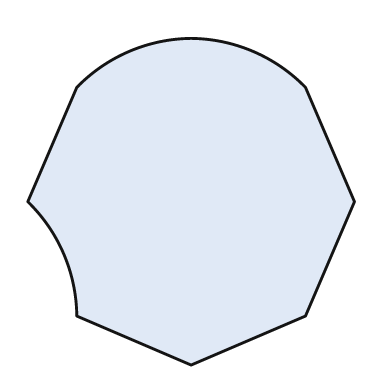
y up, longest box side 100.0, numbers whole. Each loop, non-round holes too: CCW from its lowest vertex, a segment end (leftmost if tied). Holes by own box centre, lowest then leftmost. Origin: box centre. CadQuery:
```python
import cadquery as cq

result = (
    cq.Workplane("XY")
    .moveTo(0.0, -50.0)
    .lineTo(35.0, -35.0)
    .lineTo(50.0, 0.0)
    .lineTo(35.0, 35.0)
    .threePointArc((19.0, 46.0), (0.0, 50.0))
    .threePointArc((-19.0, 46.0), (-35.0, 35.0))
    .lineTo(-50.0, 0.0)
    .threePointArc((-39.0, -16.0), (-35.0, -35.0))
    .close()
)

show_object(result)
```